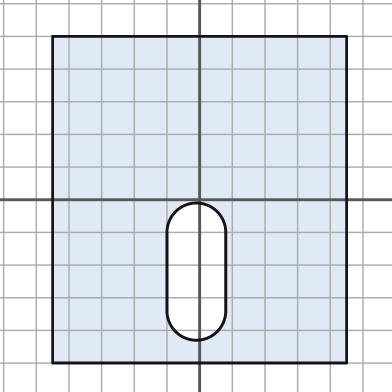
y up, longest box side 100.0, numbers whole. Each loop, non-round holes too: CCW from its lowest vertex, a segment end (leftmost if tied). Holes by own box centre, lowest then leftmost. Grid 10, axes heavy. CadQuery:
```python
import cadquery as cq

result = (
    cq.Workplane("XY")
    .moveTo(-45.0, -50.0)
    .lineTo(45.0, -50.0)
    .lineTo(45.0, 50.0)
    .lineTo(-45.0, 50.0)
    .close()
    .moveTo(-10.0, -34.0)
    .threePointArc((-1.0, -43.0), (8.0, -34.0))
    .lineTo(8.0, -10.0)
    .threePointArc((-1.0, -1.0), (-10.0, -10.0))
    .close()
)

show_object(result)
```